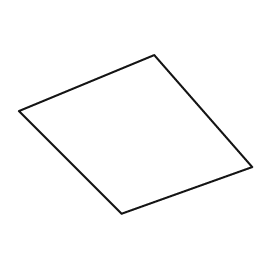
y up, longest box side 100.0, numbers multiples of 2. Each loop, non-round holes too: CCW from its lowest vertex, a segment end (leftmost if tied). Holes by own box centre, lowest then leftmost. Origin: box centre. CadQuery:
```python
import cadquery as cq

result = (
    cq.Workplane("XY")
    .moveTo(-6.0, -34.0)
    .lineTo(50.0, -14.0)
    .lineTo(8.0, 34.0)
    .lineTo(-50.0, 10.0)
    .close()
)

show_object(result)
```